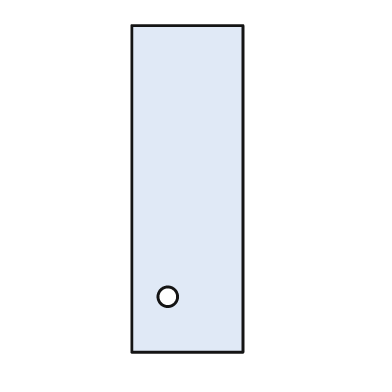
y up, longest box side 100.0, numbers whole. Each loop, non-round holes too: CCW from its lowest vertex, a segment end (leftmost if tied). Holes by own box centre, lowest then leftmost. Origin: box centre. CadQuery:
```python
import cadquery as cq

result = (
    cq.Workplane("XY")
    .moveTo(-17.0, -50.0)
    .lineTo(17.0, -50.0)
    .lineTo(17.0, 50.0)
    .lineTo(-17.0, 50.0)
    .close()
    .moveTo(-6.0, -33.0)
    .circle(3.0)
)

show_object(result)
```